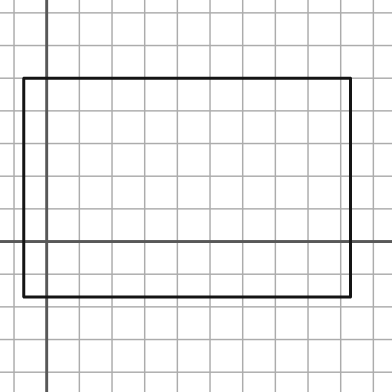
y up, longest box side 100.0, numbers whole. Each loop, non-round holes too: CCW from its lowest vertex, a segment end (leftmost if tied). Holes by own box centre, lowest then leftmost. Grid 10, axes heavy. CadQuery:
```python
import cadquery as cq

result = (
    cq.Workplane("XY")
    .moveTo(-7.0, -17.0)
    .lineTo(93.0, -17.0)
    .lineTo(93.0, 50.0)
    .lineTo(-7.0, 50.0)
    .close()
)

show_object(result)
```